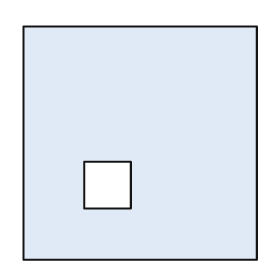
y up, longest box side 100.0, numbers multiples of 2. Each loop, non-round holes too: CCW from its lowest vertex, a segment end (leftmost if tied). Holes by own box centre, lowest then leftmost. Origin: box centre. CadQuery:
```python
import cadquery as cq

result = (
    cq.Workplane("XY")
    .moveTo(-50.0, -50.0)
    .lineTo(50.0, -50.0)
    .lineTo(50.0, 50.0)
    .lineTo(-50.0, 50.0)
    .close()
    .moveTo(-24.0, -28.0)
    .lineTo(-4.0, -28.0)
    .lineTo(-4.0, -8.0)
    .lineTo(-24.0, -8.0)
    .close()
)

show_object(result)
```